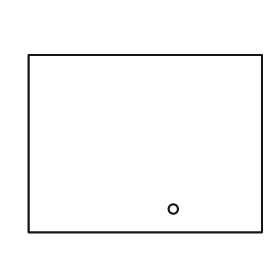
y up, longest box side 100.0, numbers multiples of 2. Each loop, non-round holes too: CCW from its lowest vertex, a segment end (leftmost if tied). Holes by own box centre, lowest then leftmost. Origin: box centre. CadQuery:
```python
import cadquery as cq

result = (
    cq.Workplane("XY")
    .moveTo(-50.0, -38.0)
    .lineTo(50.0, -38.0)
    .lineTo(50.0, 38.0)
    .lineTo(-50.0, 38.0)
    .close()
    .moveTo(12.0, -28.0)
    .circle(2.0)
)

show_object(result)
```